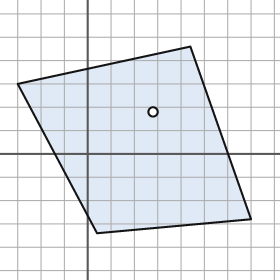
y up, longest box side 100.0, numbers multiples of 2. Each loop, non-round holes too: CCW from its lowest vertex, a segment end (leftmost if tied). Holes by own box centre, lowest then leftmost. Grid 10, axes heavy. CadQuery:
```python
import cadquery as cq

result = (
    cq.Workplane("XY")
    .moveTo(4.0, -34.0)
    .lineTo(70.0, -28.0)
    .lineTo(44.0, 46.0)
    .lineTo(-30.0, 30.0)
    .close()
    .moveTo(28.0, 18.0)
    .circle(2.0)
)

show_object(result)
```